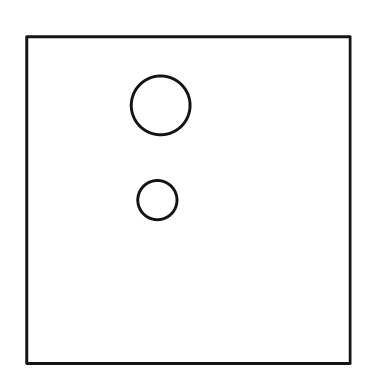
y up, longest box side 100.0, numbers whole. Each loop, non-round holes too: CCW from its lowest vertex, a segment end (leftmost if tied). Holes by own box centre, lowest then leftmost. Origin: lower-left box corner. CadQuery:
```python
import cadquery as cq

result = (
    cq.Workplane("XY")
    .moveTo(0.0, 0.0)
    .lineTo(99.0, 0.0)
    .lineTo(99.0, 100.0)
    .lineTo(0.0, 100.0)
    .close()
    .moveTo(40.0, 50.0)
    .circle(6.0)
    .moveTo(41.0, 79.0)
    .circle(9.0)
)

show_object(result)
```